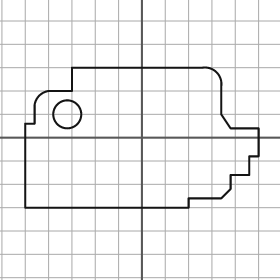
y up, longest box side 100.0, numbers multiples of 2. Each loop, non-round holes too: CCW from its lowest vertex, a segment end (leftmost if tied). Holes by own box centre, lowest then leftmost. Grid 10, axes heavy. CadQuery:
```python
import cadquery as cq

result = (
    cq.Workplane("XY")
    .moveTo(-50.0, -30.0)
    .lineTo(20.0, -30.0)
    .lineTo(20.0, -26.0)
    .lineTo(34.0, -26.0)
    .lineTo(38.0, -22.0)
    .lineTo(38.0, -16.0)
    .lineTo(46.0, -16.0)
    .lineTo(46.0, -8.0)
    .lineTo(50.0, -8.0)
    .lineTo(50.0, 4.0)
    .lineTo(38.0, 4.0)
    .lineTo(34.0, 10.0)
    .lineTo(34.0, 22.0)
    .threePointArc((32.0, 28.0), (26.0, 30.0))
    .lineTo(-30.0, 30.0)
    .lineTo(-30.0, 20.0)
    .lineTo(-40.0, 20.0)
    .threePointArc((-44.0, 18.0), (-46.0, 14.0))
    .lineTo(-46.0, 6.0)
    .lineTo(-50.0, 6.0)
    .close()
    .moveTo(-32.0, 10.0)
    .circle(6.0)
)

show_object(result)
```